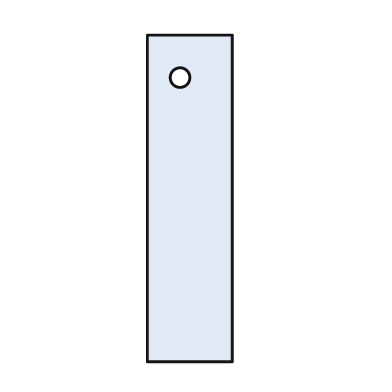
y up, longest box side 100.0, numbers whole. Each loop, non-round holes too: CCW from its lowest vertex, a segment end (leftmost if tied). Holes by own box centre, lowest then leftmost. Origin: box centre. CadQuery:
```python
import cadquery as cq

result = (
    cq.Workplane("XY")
    .moveTo(-13.0, -50.0)
    .lineTo(13.0, -50.0)
    .lineTo(13.0, 50.0)
    .lineTo(-13.0, 50.0)
    .close()
    .moveTo(-3.0, 37.0)
    .circle(3.0)
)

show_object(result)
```